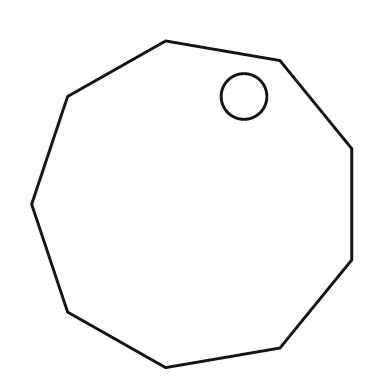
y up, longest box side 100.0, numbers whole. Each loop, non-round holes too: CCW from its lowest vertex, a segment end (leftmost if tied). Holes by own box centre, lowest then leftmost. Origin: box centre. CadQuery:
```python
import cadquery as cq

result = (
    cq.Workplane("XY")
    .moveTo(-8.0, -50.0)
    .lineTo(27.0, -44.0)
    .lineTo(49.0, -17.0)
    .lineTo(49.0, 17.0)
    .lineTo(27.0, 44.0)
    .lineTo(-8.0, 50.0)
    .lineTo(-38.0, 33.0)
    .lineTo(-49.0, 0.0)
    .lineTo(-38.0, -33.0)
    .close()
    .moveTo(16.0, 33.0)
    .circle(7.0)
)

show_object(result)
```